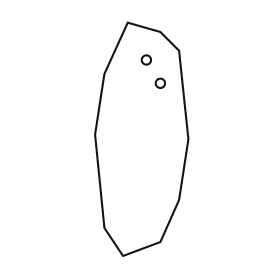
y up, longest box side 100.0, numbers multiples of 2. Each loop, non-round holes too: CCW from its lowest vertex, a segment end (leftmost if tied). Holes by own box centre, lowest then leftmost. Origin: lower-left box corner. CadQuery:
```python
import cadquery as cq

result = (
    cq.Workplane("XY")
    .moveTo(12.0, 0.0)
    .lineTo(28.0, 6.0)
    .lineTo(36.0, 24.0)
    .lineTo(40.0, 50.0)
    .lineTo(36.0, 88.0)
    .lineTo(28.0, 96.0)
    .lineTo(14.0, 100.0)
    .lineTo(4.0, 78.0)
    .lineTo(0.0, 52.0)
    .lineTo(4.0, 12.0)
    .close()
    .moveTo(28.0, 74.0)
    .circle(2.0)
    .moveTo(22.0, 84.0)
    .circle(2.0)
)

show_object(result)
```